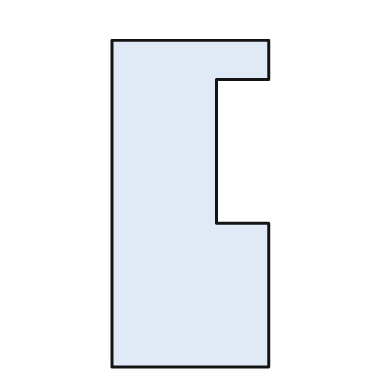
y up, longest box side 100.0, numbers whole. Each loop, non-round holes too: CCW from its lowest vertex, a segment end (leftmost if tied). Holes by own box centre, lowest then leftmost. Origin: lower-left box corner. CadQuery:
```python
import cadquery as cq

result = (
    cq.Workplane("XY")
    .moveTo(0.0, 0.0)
    .lineTo(48.0, 0.0)
    .lineTo(48.0, 44.0)
    .lineTo(32.0, 44.0)
    .lineTo(32.0, 88.0)
    .lineTo(48.0, 88.0)
    .lineTo(48.0, 100.0)
    .lineTo(0.0, 100.0)
    .close()
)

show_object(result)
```